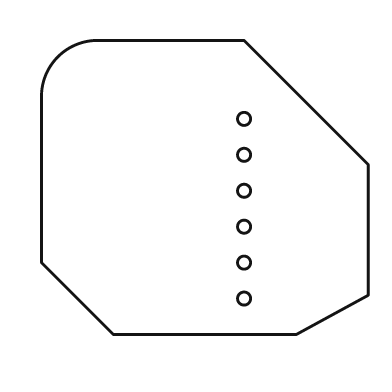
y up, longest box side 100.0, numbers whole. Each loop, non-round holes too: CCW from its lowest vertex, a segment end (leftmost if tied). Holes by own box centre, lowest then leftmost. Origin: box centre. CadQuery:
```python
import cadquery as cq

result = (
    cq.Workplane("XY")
    .moveTo(-28.0, -45.0)
    .lineTo(28.0, -45.0)
    .lineTo(50.0, -33.0)
    .lineTo(50.0, 7.0)
    .lineTo(12.0, 45.0)
    .lineTo(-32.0, 45.0)
    .threePointArc((-45.0, 40.0), (-50.0, 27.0))
    .lineTo(-50.0, -23.0)
    .close()
    .moveTo(12.0, -34.0)
    .circle(2.0)
    .moveTo(12.0, -23.0)
    .circle(2.0)
    .moveTo(12.0, -12.0)
    .circle(2.0)
    .moveTo(12.0, -1.0)
    .circle(2.0)
    .moveTo(12.0, 10.0)
    .circle(2.0)
    .moveTo(12.0, 21.0)
    .circle(2.0)
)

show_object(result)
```